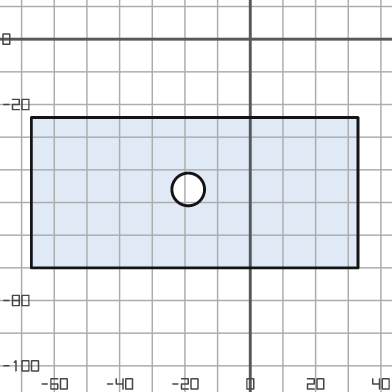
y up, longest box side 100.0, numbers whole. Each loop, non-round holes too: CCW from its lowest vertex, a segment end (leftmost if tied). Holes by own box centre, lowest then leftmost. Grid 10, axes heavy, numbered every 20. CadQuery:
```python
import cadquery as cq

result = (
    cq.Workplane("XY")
    .moveTo(-67.0, -70.0)
    .lineTo(33.0, -70.0)
    .lineTo(33.0, -24.0)
    .lineTo(-67.0, -24.0)
    .close()
    .moveTo(-19.0, -46.0)
    .circle(5.0)
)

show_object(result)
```